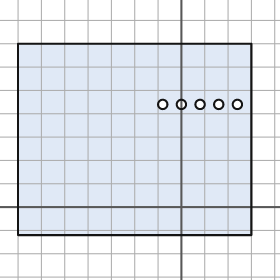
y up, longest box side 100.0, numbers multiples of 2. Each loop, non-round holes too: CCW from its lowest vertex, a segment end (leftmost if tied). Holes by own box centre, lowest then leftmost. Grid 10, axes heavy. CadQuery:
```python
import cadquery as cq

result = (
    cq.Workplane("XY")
    .moveTo(-70.0, -12.0)
    .lineTo(30.0, -12.0)
    .lineTo(30.0, 70.0)
    .lineTo(-70.0, 70.0)
    .close()
    .moveTo(-8.0, 44.0)
    .circle(2.0)
    .moveTo(0.0, 44.0)
    .circle(2.0)
    .moveTo(8.0, 44.0)
    .circle(2.0)
    .moveTo(16.0, 44.0)
    .circle(2.0)
    .moveTo(24.0, 44.0)
    .circle(2.0)
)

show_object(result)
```